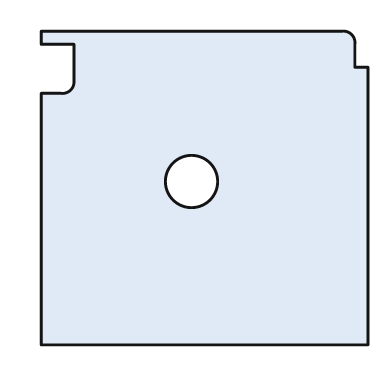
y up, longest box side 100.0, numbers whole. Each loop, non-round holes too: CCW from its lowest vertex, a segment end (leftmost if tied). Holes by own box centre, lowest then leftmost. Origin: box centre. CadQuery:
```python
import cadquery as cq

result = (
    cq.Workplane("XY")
    .moveTo(-50.0, -48.0)
    .lineTo(50.0, -48.0)
    .lineTo(50.0, 37.0)
    .lineTo(46.0, 37.0)
    .lineTo(46.0, 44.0)
    .threePointArc((45.0, 47.0), (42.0, 48.0))
    .lineTo(-50.0, 48.0)
    .lineTo(-50.0, 44.0)
    .lineTo(-40.0, 44.0)
    .lineTo(-40.0, 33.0)
    .threePointArc((-41.0, 30.0), (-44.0, 29.0))
    .lineTo(-50.0, 29.0)
    .close()
    .moveTo(-4.0, 2.0)
    .circle(8.0)
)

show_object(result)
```